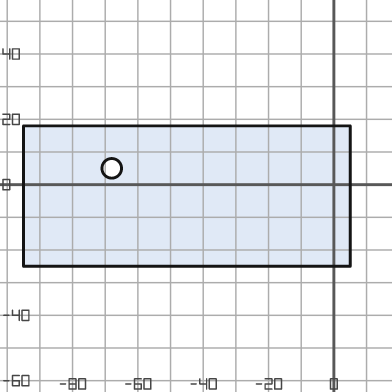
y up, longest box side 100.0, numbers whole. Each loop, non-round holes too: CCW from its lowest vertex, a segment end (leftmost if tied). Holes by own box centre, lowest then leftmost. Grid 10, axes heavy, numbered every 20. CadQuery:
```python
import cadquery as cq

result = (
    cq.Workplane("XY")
    .moveTo(-95.0, -25.0)
    .lineTo(5.0, -25.0)
    .lineTo(5.0, 18.0)
    .lineTo(-95.0, 18.0)
    .close()
    .moveTo(-68.0, 5.0)
    .circle(3.0)
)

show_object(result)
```